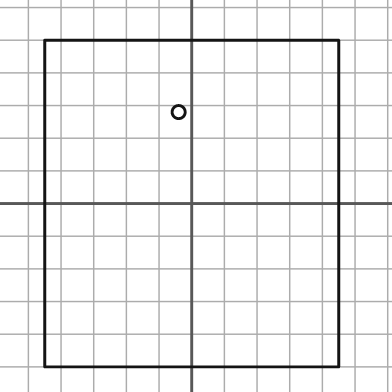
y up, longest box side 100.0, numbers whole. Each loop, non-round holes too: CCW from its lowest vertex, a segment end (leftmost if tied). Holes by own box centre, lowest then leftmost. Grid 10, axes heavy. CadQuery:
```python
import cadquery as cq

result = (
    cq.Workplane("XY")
    .moveTo(-45.0, -50.0)
    .lineTo(45.0, -50.0)
    .lineTo(45.0, 50.0)
    .lineTo(-45.0, 50.0)
    .close()
    .moveTo(-4.0, 28.0)
    .circle(2.0)
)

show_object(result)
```